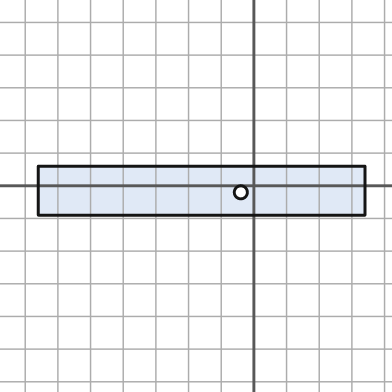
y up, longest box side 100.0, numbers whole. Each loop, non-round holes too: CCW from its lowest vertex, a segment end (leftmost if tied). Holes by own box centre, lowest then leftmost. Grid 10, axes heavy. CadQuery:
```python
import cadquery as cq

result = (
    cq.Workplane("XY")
    .moveTo(-66.0, -9.0)
    .lineTo(34.0, -9.0)
    .lineTo(34.0, 6.0)
    .lineTo(-66.0, 6.0)
    .close()
    .moveTo(-4.0, -2.0)
    .circle(2.0)
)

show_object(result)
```